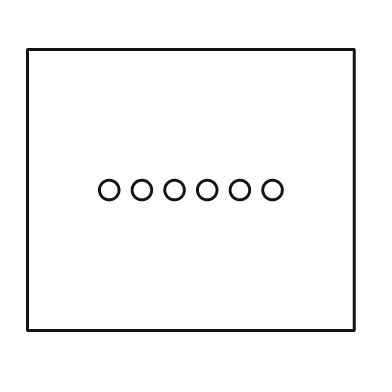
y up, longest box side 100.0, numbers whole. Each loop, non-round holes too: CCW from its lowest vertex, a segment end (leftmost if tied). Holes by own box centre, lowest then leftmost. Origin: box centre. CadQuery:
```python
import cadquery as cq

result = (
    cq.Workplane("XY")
    .moveTo(-50.0, -43.0)
    .lineTo(50.0, -43.0)
    .lineTo(50.0, 43.0)
    .lineTo(-50.0, 43.0)
    .close()
    .moveTo(-25.0, 0.0)
    .circle(3.0)
    .moveTo(-15.0, 0.0)
    .circle(3.0)
    .moveTo(-5.0, 0.0)
    .circle(3.0)
    .moveTo(5.0, 0.0)
    .circle(3.0)
    .moveTo(15.0, 0.0)
    .circle(3.0)
    .moveTo(25.0, 0.0)
    .circle(3.0)
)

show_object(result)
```